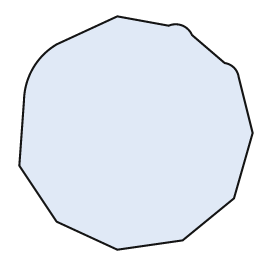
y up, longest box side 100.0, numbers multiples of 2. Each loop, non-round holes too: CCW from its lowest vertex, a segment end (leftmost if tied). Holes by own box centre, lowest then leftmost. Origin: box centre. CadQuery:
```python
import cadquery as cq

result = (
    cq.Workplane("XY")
    .moveTo(-8.0, -50.0)
    .lineTo(20.0, -46.0)
    .lineTo(42.0, -28.0)
    .lineTo(50.0, 0.0)
    .lineTo(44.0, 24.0)
    .threePointArc((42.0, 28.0), (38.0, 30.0))
    .lineTo(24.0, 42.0)
    .threePointArc((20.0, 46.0), (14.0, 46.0))
    .lineTo(-8.0, 50.0)
    .lineTo(-34.0, 38.0)
    .threePointArc((-44.0, 28.0), (-48.0, 14.0))
    .lineTo(-50.0, -14.0)
    .lineTo(-34.0, -38.0)
    .close()
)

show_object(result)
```